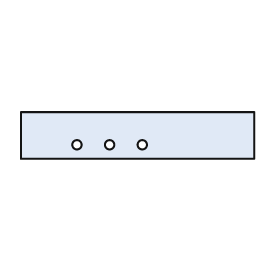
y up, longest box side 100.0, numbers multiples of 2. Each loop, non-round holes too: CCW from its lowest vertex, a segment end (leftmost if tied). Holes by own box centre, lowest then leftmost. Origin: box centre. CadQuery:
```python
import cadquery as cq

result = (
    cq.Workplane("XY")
    .moveTo(-50.0, -10.0)
    .lineTo(50.0, -10.0)
    .lineTo(50.0, 10.0)
    .lineTo(-50.0, 10.0)
    .close()
    .moveTo(-26.0, -4.0)
    .circle(2.0)
    .moveTo(-12.0, -4.0)
    .circle(2.0)
    .moveTo(2.0, -4.0)
    .circle(2.0)
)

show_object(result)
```